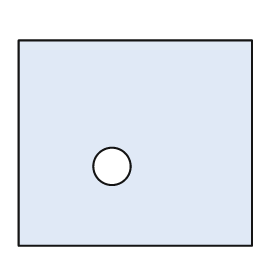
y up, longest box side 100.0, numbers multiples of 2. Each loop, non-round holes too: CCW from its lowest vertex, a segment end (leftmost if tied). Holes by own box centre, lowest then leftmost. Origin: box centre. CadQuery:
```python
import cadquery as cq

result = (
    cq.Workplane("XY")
    .moveTo(-50.0, -44.0)
    .lineTo(50.0, -44.0)
    .lineTo(50.0, 44.0)
    .lineTo(-50.0, 44.0)
    .close()
    .moveTo(-10.0, -10.0)
    .circle(8.0)
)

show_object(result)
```